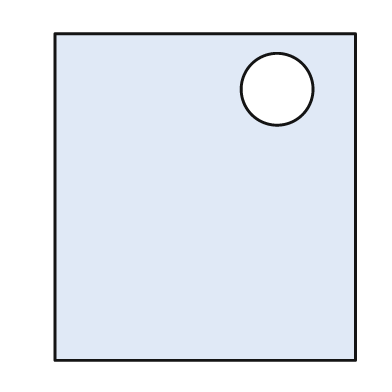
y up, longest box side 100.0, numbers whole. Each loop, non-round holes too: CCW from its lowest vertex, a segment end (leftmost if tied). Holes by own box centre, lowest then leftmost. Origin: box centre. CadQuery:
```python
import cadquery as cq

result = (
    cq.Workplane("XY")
    .moveTo(-46.0, -50.0)
    .lineTo(46.0, -50.0)
    .lineTo(46.0, 50.0)
    .lineTo(-46.0, 50.0)
    .close()
    .moveTo(22.0, 33.0)
    .circle(11.0)
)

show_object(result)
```